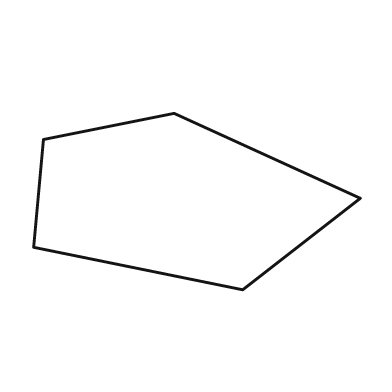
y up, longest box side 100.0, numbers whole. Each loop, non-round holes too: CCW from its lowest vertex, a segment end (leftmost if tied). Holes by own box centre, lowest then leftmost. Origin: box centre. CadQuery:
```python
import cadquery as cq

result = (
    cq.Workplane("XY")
    .moveTo(14.0, -27.0)
    .lineTo(50.0, 1.0)
    .lineTo(-7.0, 27.0)
    .lineTo(-47.0, 19.0)
    .lineTo(-50.0, -14.0)
    .close()
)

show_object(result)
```